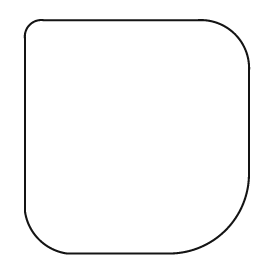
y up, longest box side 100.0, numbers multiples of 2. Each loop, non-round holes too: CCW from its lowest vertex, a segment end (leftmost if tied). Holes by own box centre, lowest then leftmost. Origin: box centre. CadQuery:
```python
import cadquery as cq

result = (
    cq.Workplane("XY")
    .moveTo(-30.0, -50.0)
    .lineTo(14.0, -50.0)
    .threePointArc((38.0, -40.0), (48.0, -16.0))
    .lineTo(48.0, 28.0)
    .threePointArc((42.0, 44.0), (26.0, 50.0))
    .lineTo(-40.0, 50.0)
    .threePointArc((-46.0, 48.0), (-48.0, 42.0))
    .lineTo(-48.0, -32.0)
    .threePointArc((-42.0, -44.0), (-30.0, -50.0))
    .close()
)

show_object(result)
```